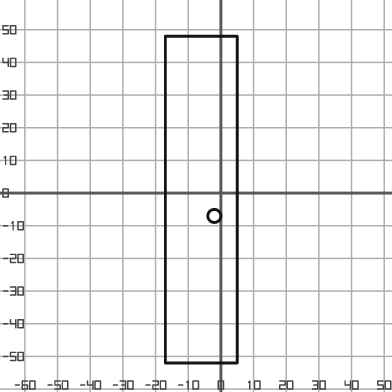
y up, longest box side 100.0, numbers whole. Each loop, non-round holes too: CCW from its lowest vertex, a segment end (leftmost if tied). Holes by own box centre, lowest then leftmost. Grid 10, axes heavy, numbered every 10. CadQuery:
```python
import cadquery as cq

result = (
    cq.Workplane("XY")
    .moveTo(-17.0, -52.0)
    .lineTo(5.0, -52.0)
    .lineTo(5.0, 48.0)
    .lineTo(-17.0, 48.0)
    .close()
    .moveTo(-2.0, -7.0)
    .circle(2.0)
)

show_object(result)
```